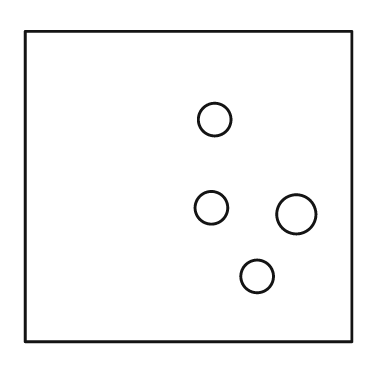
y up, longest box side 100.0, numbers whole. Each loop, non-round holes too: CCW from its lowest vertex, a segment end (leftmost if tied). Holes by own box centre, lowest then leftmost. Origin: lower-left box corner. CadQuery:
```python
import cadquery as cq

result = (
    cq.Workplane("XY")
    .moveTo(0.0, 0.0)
    .lineTo(100.0, 0.0)
    .lineTo(100.0, 95.0)
    .lineTo(0.0, 95.0)
    .close()
    .moveTo(71.0, 20.0)
    .circle(5.0)
    .moveTo(83.0, 39.0)
    .circle(6.0)
    .moveTo(57.0, 41.0)
    .circle(5.0)
    .moveTo(58.0, 68.0)
    .circle(5.0)
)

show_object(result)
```